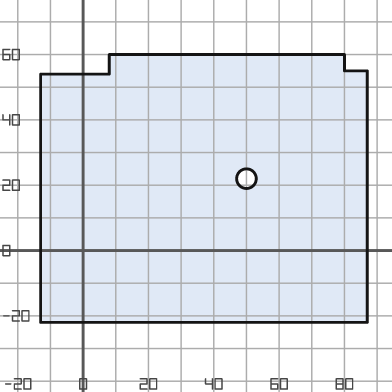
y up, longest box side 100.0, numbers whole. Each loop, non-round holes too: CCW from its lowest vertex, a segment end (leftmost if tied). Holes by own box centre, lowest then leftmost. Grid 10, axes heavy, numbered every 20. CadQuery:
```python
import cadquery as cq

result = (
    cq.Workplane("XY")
    .moveTo(-13.0, -22.0)
    .lineTo(87.0, -22.0)
    .lineTo(87.0, 55.0)
    .lineTo(80.0, 55.0)
    .lineTo(80.0, 60.0)
    .lineTo(8.0, 60.0)
    .lineTo(8.0, 54.0)
    .lineTo(-13.0, 54.0)
    .close()
    .moveTo(50.0, 22.0)
    .circle(3.0)
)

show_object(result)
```